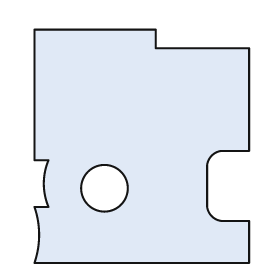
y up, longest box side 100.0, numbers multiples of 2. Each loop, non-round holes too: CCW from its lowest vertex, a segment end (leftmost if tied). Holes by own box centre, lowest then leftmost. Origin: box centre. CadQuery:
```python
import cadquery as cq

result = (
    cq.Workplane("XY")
    .moveTo(-46.0, -50.0)
    .lineTo(46.0, -50.0)
    .lineTo(46.0, -32.0)
    .lineTo(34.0, -32.0)
    .threePointArc((30.0, -30.0), (28.0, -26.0))
    .lineTo(28.0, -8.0)
    .threePointArc((30.0, -4.0), (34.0, -2.0))
    .lineTo(46.0, -2.0)
    .lineTo(46.0, 42.0)
    .lineTo(6.0, 42.0)
    .lineTo(6.0, 50.0)
    .lineTo(-46.0, 50.0)
    .lineTo(-46.0, -6.0)
    .lineTo(-40.0, -6.0)
    .threePointArc((-42.0, -16.0), (-40.0, -26.0))
    .lineTo(-46.0, -26.0)
    .threePointArc((-44.0, -38.0), (-46.0, -50.0))
    .close()
    .moveTo(-16.0, -18.0)
    .circle(10.0)
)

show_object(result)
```